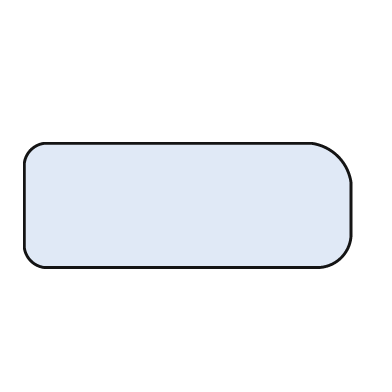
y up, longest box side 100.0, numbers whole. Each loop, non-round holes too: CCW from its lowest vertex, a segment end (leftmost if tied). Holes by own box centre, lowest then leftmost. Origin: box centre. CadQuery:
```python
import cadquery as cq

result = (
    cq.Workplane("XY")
    .moveTo(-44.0, -19.0)
    .lineTo(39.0, -19.0)
    .threePointArc((47.0, -16.0), (50.0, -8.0))
    .lineTo(50.0, 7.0)
    .threePointArc((46.0, 15.0), (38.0, 19.0))
    .lineTo(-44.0, 19.0)
    .threePointArc((-48.0, 17.0), (-50.0, 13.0))
    .lineTo(-50.0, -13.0)
    .threePointArc((-48.0, -17.0), (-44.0, -19.0))
    .close()
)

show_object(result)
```